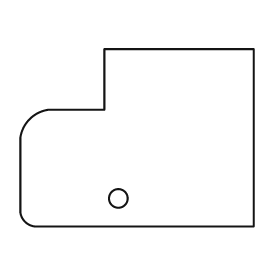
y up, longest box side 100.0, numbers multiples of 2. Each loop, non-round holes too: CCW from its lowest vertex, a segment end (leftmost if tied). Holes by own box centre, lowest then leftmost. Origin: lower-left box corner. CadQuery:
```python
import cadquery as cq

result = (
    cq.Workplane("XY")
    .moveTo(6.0, 0.0)
    .lineTo(100.0, 0.0)
    .lineTo(100.0, 76.0)
    .lineTo(36.0, 76.0)
    .lineTo(36.0, 50.0)
    .lineTo(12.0, 50.0)
    .threePointArc((4.0, 46.0), (0.0, 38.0))
    .lineTo(0.0, 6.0)
    .threePointArc((2.0, 2.0), (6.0, 0.0))
    .close()
    .moveTo(42.0, 12.0)
    .circle(4.0)
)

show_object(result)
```